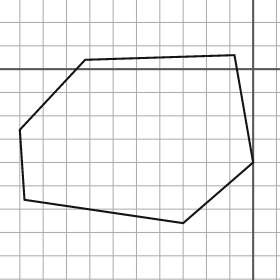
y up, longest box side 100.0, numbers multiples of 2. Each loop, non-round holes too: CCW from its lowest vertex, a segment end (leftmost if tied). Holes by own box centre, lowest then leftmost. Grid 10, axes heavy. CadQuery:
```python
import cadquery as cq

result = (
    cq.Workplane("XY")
    .moveTo(-30.0, -66.0)
    .lineTo(0.0, -40.0)
    .lineTo(-8.0, 6.0)
    .lineTo(-72.0, 4.0)
    .lineTo(-100.0, -26.0)
    .lineTo(-98.0, -56.0)
    .close()
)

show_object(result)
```